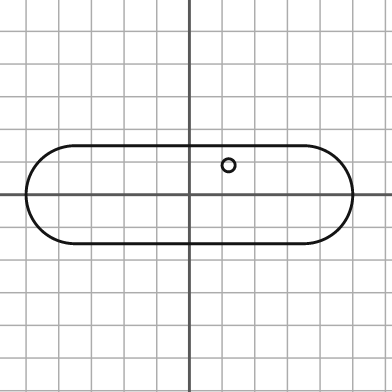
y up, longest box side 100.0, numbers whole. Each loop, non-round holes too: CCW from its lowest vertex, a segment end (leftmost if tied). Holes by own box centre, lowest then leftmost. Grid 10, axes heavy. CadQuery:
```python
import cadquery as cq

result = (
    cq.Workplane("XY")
    .moveTo(-35.0, -15.0)
    .lineTo(35.0, -15.0)
    .threePointArc((50.0, 0.0), (35.0, 15.0))
    .lineTo(-35.0, 15.0)
    .threePointArc((-50.0, 0.0), (-35.0, -15.0))
    .close()
    .moveTo(12.0, 9.0)
    .circle(2.0)
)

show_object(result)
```